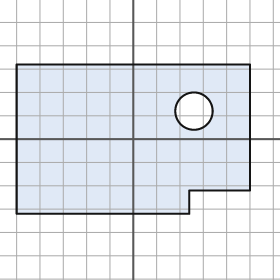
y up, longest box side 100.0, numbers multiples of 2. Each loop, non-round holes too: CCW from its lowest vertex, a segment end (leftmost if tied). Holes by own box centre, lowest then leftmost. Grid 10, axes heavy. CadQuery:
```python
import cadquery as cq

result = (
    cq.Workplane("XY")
    .moveTo(-50.0, -32.0)
    .lineTo(24.0, -32.0)
    .lineTo(24.0, -22.0)
    .lineTo(50.0, -22.0)
    .lineTo(50.0, 32.0)
    .lineTo(-50.0, 32.0)
    .close()
    .moveTo(26.0, 12.0)
    .circle(8.0)
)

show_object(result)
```